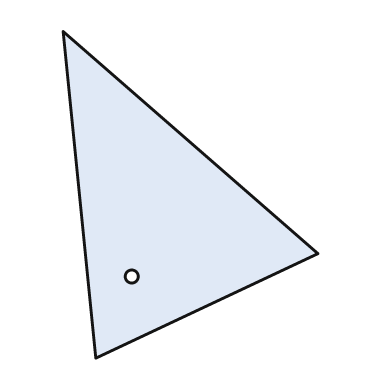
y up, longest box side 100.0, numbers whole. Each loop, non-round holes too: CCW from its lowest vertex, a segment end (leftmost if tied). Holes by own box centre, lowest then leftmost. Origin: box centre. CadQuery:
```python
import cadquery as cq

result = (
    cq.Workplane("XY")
    .moveTo(-29.0, -50.0)
    .lineTo(39.0, -18.0)
    .lineTo(-39.0, 50.0)
    .close()
    .moveTo(-18.0, -25.0)
    .circle(2.0)
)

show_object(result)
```